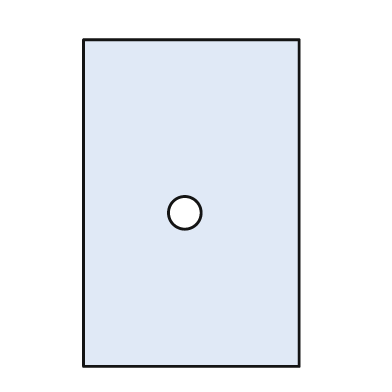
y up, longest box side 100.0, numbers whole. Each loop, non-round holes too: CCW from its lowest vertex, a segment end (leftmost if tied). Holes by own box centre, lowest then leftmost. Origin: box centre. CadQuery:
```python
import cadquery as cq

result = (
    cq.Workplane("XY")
    .moveTo(-33.0, -50.0)
    .lineTo(33.0, -50.0)
    .lineTo(33.0, 50.0)
    .lineTo(-33.0, 50.0)
    .close()
    .moveTo(-2.0, -3.0)
    .circle(5.0)
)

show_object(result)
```